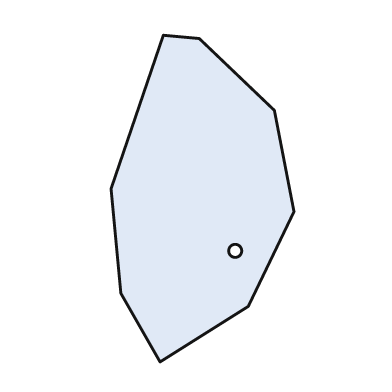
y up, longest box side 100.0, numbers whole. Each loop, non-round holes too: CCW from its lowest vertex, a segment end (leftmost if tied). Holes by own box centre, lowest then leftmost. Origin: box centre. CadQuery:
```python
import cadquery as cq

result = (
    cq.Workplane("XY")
    .moveTo(-13.0, -50.0)
    .lineTo(14.0, -33.0)
    .lineTo(28.0, -4.0)
    .lineTo(22.0, 27.0)
    .lineTo(-1.0, 49.0)
    .lineTo(-12.0, 50.0)
    .lineTo(-28.0, 3.0)
    .lineTo(-25.0, -29.0)
    .close()
    .moveTo(10.0, -16.0)
    .circle(2.0)
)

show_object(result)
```